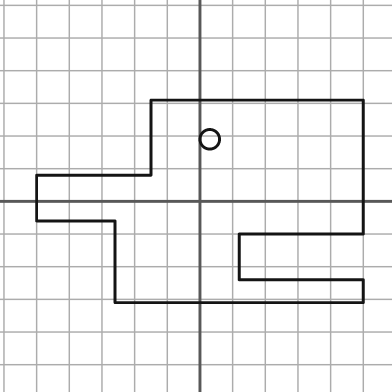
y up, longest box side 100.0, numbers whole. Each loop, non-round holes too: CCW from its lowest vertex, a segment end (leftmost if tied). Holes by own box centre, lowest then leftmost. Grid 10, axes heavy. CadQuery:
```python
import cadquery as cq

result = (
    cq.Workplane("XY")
    .moveTo(-26.0, -31.0)
    .lineTo(50.0, -31.0)
    .lineTo(50.0, -24.0)
    .lineTo(12.0, -24.0)
    .lineTo(12.0, -10.0)
    .lineTo(50.0, -10.0)
    .lineTo(50.0, 31.0)
    .lineTo(-15.0, 31.0)
    .lineTo(-15.0, 8.0)
    .lineTo(-50.0, 8.0)
    .lineTo(-50.0, -6.0)
    .lineTo(-26.0, -6.0)
    .close()
    .moveTo(3.0, 19.0)
    .circle(3.0)
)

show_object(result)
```